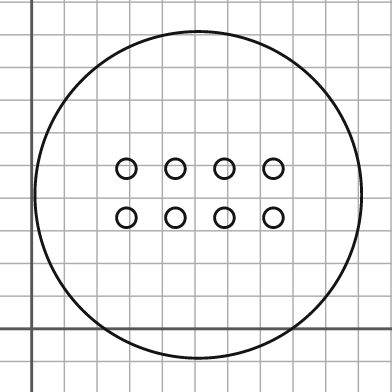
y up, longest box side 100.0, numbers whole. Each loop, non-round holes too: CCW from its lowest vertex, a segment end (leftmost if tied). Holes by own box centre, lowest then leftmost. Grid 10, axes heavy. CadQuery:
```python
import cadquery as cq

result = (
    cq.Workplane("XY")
    .moveTo(51.0, 41.0)
    .circle(50.0)
    .moveTo(29.0, 34.0)
    .circle(3.0)
    .moveTo(44.0, 34.0)
    .circle(3.0)
    .moveTo(59.0, 34.0)
    .circle(3.0)
    .moveTo(74.0, 34.0)
    .circle(3.0)
    .moveTo(29.0, 49.0)
    .circle(3.0)
    .moveTo(44.0, 49.0)
    .circle(3.0)
    .moveTo(59.0, 49.0)
    .circle(3.0)
    .moveTo(74.0, 49.0)
    .circle(3.0)
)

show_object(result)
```